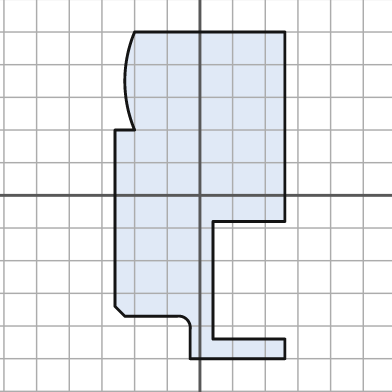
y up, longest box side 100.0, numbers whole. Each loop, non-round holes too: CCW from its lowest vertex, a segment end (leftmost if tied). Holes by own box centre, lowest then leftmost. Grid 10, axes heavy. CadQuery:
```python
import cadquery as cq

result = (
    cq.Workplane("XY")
    .moveTo(-3.0, -50.0)
    .lineTo(26.0, -50.0)
    .lineTo(26.0, -44.0)
    .lineTo(4.0, -44.0)
    .lineTo(4.0, -8.0)
    .lineTo(26.0, -8.0)
    .lineTo(26.0, 50.0)
    .lineTo(-20.0, 50.0)
    .threePointArc((-23.0, 35.0), (-20.0, 20.0))
    .lineTo(-26.0, 20.0)
    .lineTo(-26.0, -34.0)
    .lineTo(-23.0, -37.0)
    .lineTo(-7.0, -37.0)
    .threePointArc((-4.0, -38.0), (-3.0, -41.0))
    .close()
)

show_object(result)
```